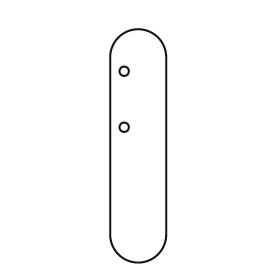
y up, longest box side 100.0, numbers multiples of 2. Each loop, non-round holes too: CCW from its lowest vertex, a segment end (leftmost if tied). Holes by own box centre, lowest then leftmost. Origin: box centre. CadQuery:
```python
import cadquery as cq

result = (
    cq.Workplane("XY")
    .moveTo(-12.0, -38.0)
    .threePointArc((0.0, -50.0), (12.0, -38.0))
    .lineTo(12.0, 38.0)
    .threePointArc((0.0, 50.0), (-12.0, 38.0))
    .close()
    .moveTo(-6.0, 8.0)
    .circle(2.0)
    .moveTo(-6.0, 32.0)
    .circle(2.0)
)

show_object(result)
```